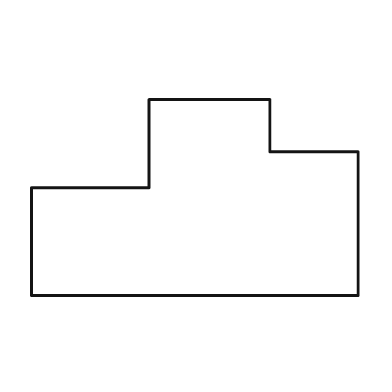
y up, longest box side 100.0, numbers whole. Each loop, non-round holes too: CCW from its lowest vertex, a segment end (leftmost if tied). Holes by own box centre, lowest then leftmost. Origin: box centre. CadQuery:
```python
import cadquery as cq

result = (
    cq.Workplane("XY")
    .moveTo(-50.0, -30.0)
    .lineTo(50.0, -30.0)
    .lineTo(50.0, 14.0)
    .lineTo(23.0, 14.0)
    .lineTo(23.0, 30.0)
    .lineTo(-14.0, 30.0)
    .lineTo(-14.0, 3.0)
    .lineTo(-50.0, 3.0)
    .close()
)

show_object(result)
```